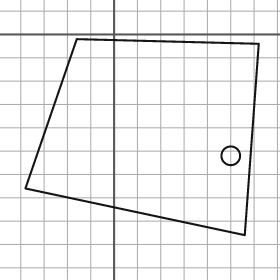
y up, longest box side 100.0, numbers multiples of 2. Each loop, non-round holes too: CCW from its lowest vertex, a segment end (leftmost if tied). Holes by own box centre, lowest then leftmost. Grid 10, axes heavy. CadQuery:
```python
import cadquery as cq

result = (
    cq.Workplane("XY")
    .moveTo(56.0, -86.0)
    .lineTo(62.0, -4.0)
    .lineTo(-16.0, -2.0)
    .lineTo(-38.0, -66.0)
    .close()
    .moveTo(50.0, -52.0)
    .circle(4.0)
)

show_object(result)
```